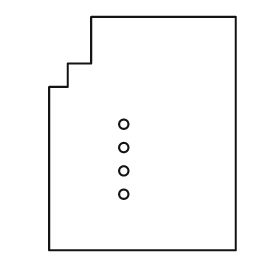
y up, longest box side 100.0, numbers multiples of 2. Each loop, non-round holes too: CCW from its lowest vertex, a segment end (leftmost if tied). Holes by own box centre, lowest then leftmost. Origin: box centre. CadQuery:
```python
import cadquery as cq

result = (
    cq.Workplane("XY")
    .moveTo(-40.0, -50.0)
    .lineTo(40.0, -50.0)
    .lineTo(40.0, 50.0)
    .lineTo(-22.0, 50.0)
    .lineTo(-22.0, 30.0)
    .lineTo(-32.0, 30.0)
    .lineTo(-32.0, 20.0)
    .lineTo(-40.0, 20.0)
    .close()
    .moveTo(-8.0, -26.0)
    .circle(2.0)
    .moveTo(-8.0, -16.0)
    .circle(2.0)
    .moveTo(-8.0, -6.0)
    .circle(2.0)
    .moveTo(-8.0, 4.0)
    .circle(2.0)
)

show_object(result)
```